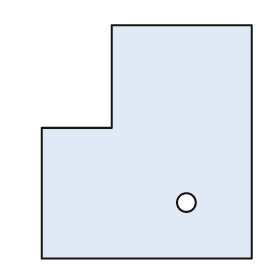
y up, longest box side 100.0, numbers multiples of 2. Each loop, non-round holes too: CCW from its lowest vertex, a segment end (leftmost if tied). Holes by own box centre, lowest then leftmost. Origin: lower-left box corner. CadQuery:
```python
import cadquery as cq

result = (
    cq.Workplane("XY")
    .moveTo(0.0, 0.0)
    .lineTo(90.0, 0.0)
    .lineTo(90.0, 100.0)
    .lineTo(30.0, 100.0)
    .lineTo(30.0, 56.0)
    .lineTo(0.0, 56.0)
    .close()
    .moveTo(62.0, 24.0)
    .circle(4.0)
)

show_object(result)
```